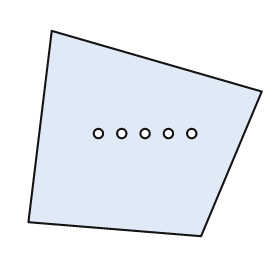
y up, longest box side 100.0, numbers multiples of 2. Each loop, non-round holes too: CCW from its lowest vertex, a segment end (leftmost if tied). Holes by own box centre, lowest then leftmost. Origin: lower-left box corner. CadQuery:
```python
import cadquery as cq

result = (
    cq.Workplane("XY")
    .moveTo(74.0, 0.0)
    .lineTo(100.0, 62.0)
    .lineTo(10.0, 88.0)
    .lineTo(0.0, 6.0)
    .close()
    .moveTo(30.0, 44.0)
    .circle(2.0)
    .moveTo(40.0, 44.0)
    .circle(2.0)
    .moveTo(50.0, 44.0)
    .circle(2.0)
    .moveTo(60.0, 44.0)
    .circle(2.0)
    .moveTo(70.0, 44.0)
    .circle(2.0)
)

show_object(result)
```